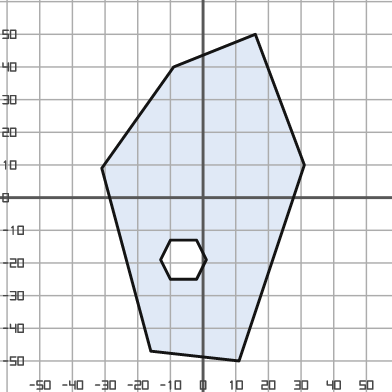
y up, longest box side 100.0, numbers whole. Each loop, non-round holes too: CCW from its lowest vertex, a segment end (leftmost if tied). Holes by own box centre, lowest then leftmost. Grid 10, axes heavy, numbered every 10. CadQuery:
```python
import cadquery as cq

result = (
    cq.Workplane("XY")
    .moveTo(11.0, -50.0)
    .lineTo(31.0, 10.0)
    .lineTo(16.0, 50.0)
    .lineTo(-9.0, 40.0)
    .lineTo(-31.0, 9.0)
    .lineTo(-16.0, -47.0)
    .close()
    .moveTo(-10.0, -25.0)
    .lineTo(-2.0, -25.0)
    .lineTo(1.0, -19.0)
    .lineTo(-2.0, -13.0)
    .lineTo(-10.0, -13.0)
    .lineTo(-13.0, -19.0)
    .close()
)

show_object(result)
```